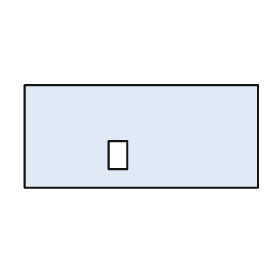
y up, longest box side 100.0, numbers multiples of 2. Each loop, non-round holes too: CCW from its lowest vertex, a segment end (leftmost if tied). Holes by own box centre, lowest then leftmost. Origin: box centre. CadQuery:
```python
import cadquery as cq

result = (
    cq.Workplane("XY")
    .moveTo(-50.0, -22.0)
    .lineTo(50.0, -22.0)
    .lineTo(50.0, 22.0)
    .lineTo(-50.0, 22.0)
    .close()
    .moveTo(-14.0, -14.0)
    .lineTo(-6.0, -14.0)
    .lineTo(-6.0, -2.0)
    .lineTo(-14.0, -2.0)
    .close()
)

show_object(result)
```